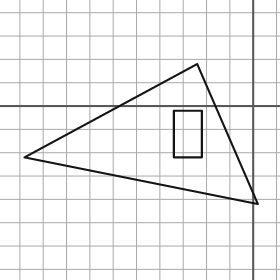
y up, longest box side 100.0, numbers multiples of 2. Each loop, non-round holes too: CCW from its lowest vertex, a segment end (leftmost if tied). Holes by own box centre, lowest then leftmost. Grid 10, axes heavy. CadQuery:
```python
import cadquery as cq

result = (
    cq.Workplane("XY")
    .moveTo(2.0, -42.0)
    .lineTo(-24.0, 18.0)
    .lineTo(-98.0, -22.0)
    .close()
    .moveTo(-34.0, -22.0)
    .lineTo(-22.0, -22.0)
    .lineTo(-22.0, -2.0)
    .lineTo(-34.0, -2.0)
    .close()
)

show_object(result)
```